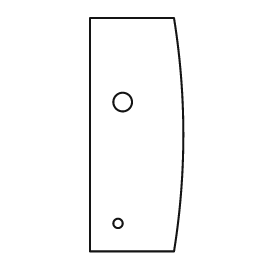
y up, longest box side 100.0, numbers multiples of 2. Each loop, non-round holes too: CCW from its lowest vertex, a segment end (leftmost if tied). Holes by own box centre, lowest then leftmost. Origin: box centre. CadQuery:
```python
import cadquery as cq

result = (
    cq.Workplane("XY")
    .moveTo(-20.0, -50.0)
    .lineTo(16.0, -50.0)
    .threePointArc((20.0, 0.0), (16.0, 50.0))
    .lineTo(-20.0, 50.0)
    .close()
    .moveTo(-8.0, -38.0)
    .circle(2.0)
    .moveTo(-6.0, 14.0)
    .circle(4.0)
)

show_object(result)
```